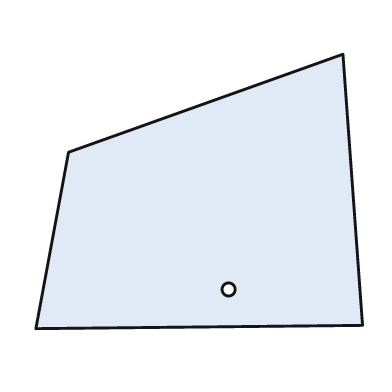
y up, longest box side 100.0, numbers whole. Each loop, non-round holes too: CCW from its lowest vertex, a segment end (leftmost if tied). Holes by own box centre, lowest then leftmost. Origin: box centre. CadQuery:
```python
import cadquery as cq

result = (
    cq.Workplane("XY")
    .moveTo(-50.0, -42.0)
    .lineTo(50.0, -41.0)
    .lineTo(44.0, 42.0)
    .lineTo(-40.0, 12.0)
    .close()
    .moveTo(9.0, -30.0)
    .circle(2.0)
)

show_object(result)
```